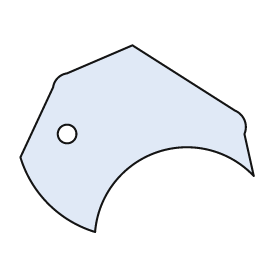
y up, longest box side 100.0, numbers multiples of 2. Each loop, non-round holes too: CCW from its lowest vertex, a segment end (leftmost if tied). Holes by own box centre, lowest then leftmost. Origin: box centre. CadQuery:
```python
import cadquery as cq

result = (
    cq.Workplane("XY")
    .moveTo(-18.0, -40.0)
    .threePointArc((8.0, -6.0), (50.0, -16.0))
    .lineTo(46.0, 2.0)
    .threePointArc((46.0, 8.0), (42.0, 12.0))
    .lineTo(-2.0, 40.0)
    .lineTo(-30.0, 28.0)
    .threePointArc((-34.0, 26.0), (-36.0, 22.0))
    .lineTo(-50.0, -8.0)
    .threePointArc((-38.0, -28.0), (-18.0, -40.0))
    .close()
    .moveTo(-30.0, 2.0)
    .circle(4.0)
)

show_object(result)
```